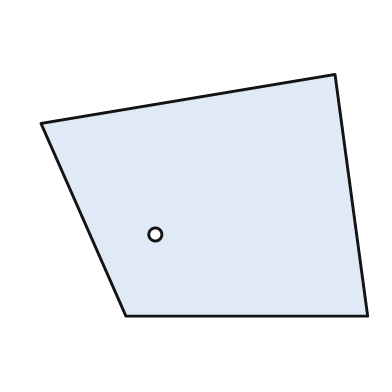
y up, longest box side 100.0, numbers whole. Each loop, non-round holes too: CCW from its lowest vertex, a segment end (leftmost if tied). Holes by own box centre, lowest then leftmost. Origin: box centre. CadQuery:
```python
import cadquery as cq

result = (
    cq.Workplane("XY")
    .moveTo(-24.0, -37.0)
    .lineTo(50.0, -37.0)
    .lineTo(40.0, 37.0)
    .lineTo(-50.0, 22.0)
    .close()
    .moveTo(-15.0, -12.0)
    .circle(2.0)
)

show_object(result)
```